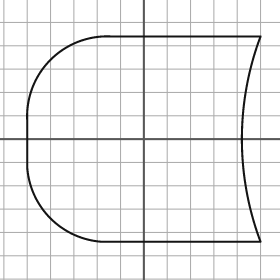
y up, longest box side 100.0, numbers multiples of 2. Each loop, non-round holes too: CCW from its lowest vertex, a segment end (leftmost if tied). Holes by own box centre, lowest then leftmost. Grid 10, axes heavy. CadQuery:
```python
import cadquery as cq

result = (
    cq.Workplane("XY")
    .moveTo(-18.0, -44.0)
    .lineTo(50.0, -44.0)
    .threePointArc((42.0, 0.0), (50.0, 44.0))
    .lineTo(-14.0, 44.0)
    .threePointArc((-40.0, 34.0), (-50.0, 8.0))
    .lineTo(-50.0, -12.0)
    .threePointArc((-40.0, -34.0), (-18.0, -44.0))
    .close()
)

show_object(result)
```